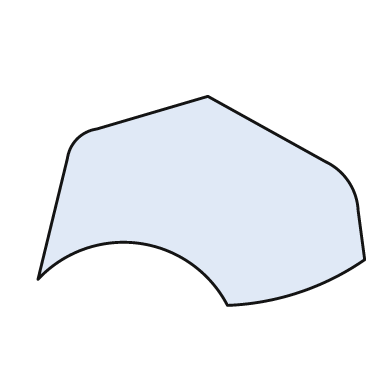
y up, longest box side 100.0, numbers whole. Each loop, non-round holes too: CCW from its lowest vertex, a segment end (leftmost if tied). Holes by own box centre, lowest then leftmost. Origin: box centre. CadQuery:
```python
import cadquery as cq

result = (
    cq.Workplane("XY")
    .moveTo(8.0, -32.0)
    .threePointArc((30.0, -28.0), (50.0, -18.0))
    .lineTo(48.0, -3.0)
    .threePointArc((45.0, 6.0), (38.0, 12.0))
    .lineTo(2.0, 32.0)
    .lineTo(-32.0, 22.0)
    .threePointArc((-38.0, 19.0), (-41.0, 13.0))
    .lineTo(-50.0, -24.0)
    .threePointArc((-19.0, -13.0), (8.0, -32.0))
    .close()
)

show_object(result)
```